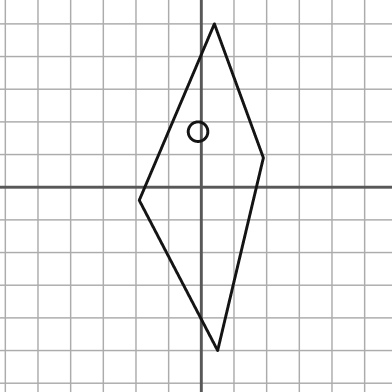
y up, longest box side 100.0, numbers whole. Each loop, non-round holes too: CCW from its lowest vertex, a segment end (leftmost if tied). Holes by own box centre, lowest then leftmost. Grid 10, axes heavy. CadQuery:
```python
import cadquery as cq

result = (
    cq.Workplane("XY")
    .moveTo(5.0, -50.0)
    .lineTo(19.0, 9.0)
    .lineTo(4.0, 50.0)
    .lineTo(-19.0, -4.0)
    .close()
    .moveTo(-1.0, 17.0)
    .circle(3.0)
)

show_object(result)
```